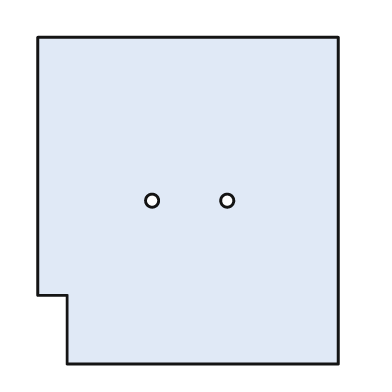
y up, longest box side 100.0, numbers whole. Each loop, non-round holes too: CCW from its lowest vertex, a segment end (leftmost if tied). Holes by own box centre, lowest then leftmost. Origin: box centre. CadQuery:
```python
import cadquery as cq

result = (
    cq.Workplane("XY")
    .moveTo(-37.0, -50.0)
    .lineTo(46.0, -50.0)
    .lineTo(46.0, 50.0)
    .lineTo(-46.0, 50.0)
    .lineTo(-46.0, -29.0)
    .lineTo(-37.0, -29.0)
    .close()
    .moveTo(-11.0, 0.0)
    .circle(2.0)
    .moveTo(12.0, 0.0)
    .circle(2.0)
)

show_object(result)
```